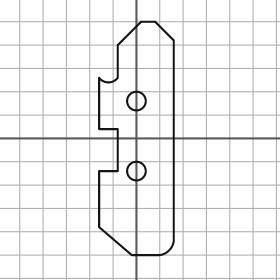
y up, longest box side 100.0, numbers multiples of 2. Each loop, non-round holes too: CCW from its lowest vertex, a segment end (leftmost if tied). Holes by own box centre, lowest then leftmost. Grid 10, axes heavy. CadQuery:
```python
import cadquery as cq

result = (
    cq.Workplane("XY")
    .moveTo(-2.0, -50.0)
    .lineTo(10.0, -50.0)
    .threePointArc((14.0, -48.0), (16.0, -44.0))
    .lineTo(16.0, 42.0)
    .lineTo(8.0, 50.0)
    .lineTo(2.0, 50.0)
    .lineTo(-8.0, 40.0)
    .lineTo(-8.0, 26.0)
    .threePointArc((-12.0, 24.0), (-16.0, 26.0))
    .lineTo(-16.0, 4.0)
    .lineTo(-8.0, 4.0)
    .lineTo(-8.0, -14.0)
    .lineTo(-16.0, -14.0)
    .lineTo(-16.0, -38.0)
    .close()
    .moveTo(0.0, -14.0)
    .circle(4.0)
    .moveTo(0.0, 16.0)
    .circle(4.0)
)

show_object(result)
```